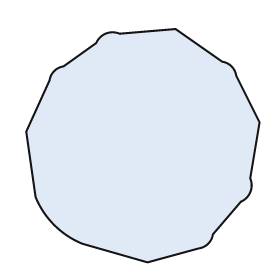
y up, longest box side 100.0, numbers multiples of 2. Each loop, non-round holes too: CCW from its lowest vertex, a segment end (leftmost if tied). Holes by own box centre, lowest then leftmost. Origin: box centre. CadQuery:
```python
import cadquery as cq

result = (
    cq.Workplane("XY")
    .moveTo(2.0, -50.0)
    .lineTo(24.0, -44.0)
    .threePointArc((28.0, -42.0), (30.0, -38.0))
    .lineTo(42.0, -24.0)
    .threePointArc((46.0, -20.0), (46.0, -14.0))
    .lineTo(50.0, 10.0)
    .lineTo(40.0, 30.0)
    .threePointArc((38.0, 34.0), (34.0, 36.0))
    .lineTo(14.0, 50.0)
    .lineTo(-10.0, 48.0)
    .threePointArc((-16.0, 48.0), (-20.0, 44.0))
    .lineTo(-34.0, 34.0)
    .threePointArc((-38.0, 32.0), (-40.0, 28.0))
    .lineTo(-50.0, 6.0)
    .lineTo(-46.0, -22.0)
    .threePointArc((-38.0, -34.0), (-26.0, -42.0))
    .close()
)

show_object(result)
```